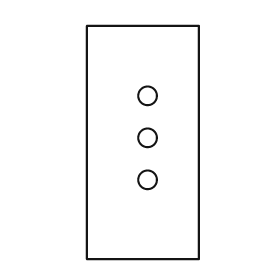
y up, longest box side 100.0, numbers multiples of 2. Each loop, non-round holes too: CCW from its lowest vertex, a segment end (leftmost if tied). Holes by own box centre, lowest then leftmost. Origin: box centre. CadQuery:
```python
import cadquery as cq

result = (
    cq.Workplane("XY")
    .moveTo(-24.0, -50.0)
    .lineTo(24.0, -50.0)
    .lineTo(24.0, 50.0)
    .lineTo(-24.0, 50.0)
    .close()
    .moveTo(2.0, -16.0)
    .circle(4.0)
    .moveTo(2.0, 2.0)
    .circle(4.0)
    .moveTo(2.0, 20.0)
    .circle(4.0)
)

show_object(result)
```